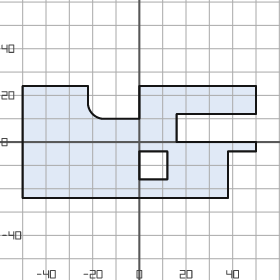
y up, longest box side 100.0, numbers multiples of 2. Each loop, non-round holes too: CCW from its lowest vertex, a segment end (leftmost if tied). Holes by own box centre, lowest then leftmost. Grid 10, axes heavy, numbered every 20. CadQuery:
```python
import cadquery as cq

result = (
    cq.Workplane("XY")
    .moveTo(-50.0, -24.0)
    .lineTo(38.0, -24.0)
    .lineTo(38.0, -4.0)
    .lineTo(50.0, -4.0)
    .lineTo(50.0, 0.0)
    .lineTo(16.0, 0.0)
    .lineTo(16.0, 12.0)
    .lineTo(50.0, 12.0)
    .lineTo(50.0, 24.0)
    .lineTo(0.0, 24.0)
    .lineTo(0.0, 10.0)
    .lineTo(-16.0, 10.0)
    .threePointArc((-20.0, 12.0), (-22.0, 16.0))
    .lineTo(-22.0, 24.0)
    .lineTo(-50.0, 24.0)
    .close()
    .moveTo(0.0, -16.0)
    .lineTo(12.0, -16.0)
    .lineTo(12.0, -4.0)
    .lineTo(0.0, -4.0)
    .close()
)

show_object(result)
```